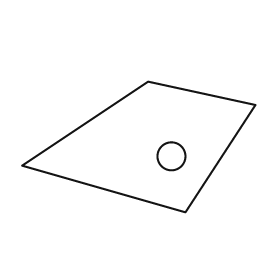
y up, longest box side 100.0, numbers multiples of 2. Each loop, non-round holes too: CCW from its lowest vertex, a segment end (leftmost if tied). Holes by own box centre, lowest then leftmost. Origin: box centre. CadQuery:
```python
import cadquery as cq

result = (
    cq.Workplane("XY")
    .moveTo(20.0, -28.0)
    .lineTo(50.0, 18.0)
    .lineTo(4.0, 28.0)
    .lineTo(-50.0, -8.0)
    .close()
    .moveTo(14.0, -4.0)
    .circle(6.0)
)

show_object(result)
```